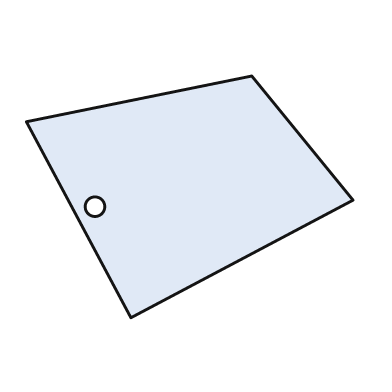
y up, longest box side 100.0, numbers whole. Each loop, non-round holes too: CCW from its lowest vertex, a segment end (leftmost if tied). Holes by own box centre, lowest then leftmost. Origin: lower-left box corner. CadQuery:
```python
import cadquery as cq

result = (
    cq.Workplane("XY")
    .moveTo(32.0, 0.0)
    .lineTo(100.0, 36.0)
    .lineTo(69.0, 74.0)
    .lineTo(0.0, 60.0)
    .close()
    .moveTo(21.0, 34.0)
    .circle(3.0)
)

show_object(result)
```